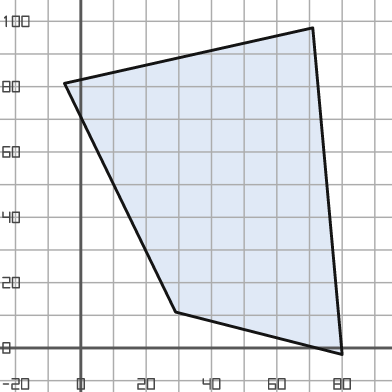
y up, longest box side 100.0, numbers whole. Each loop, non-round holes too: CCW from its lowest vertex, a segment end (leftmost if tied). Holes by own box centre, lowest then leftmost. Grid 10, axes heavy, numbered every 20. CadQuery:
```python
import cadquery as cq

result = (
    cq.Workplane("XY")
    .moveTo(80.0, -2.0)
    .lineTo(71.0, 98.0)
    .lineTo(-5.0, 81.0)
    .lineTo(29.0, 11.0)
    .close()
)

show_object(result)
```